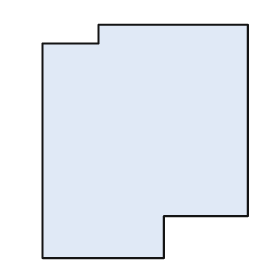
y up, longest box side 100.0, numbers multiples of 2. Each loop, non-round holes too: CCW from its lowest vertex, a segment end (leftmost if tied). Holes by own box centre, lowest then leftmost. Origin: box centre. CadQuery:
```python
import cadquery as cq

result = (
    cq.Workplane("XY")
    .moveTo(-44.0, -50.0)
    .lineTo(8.0, -50.0)
    .lineTo(8.0, -32.0)
    .lineTo(44.0, -32.0)
    .lineTo(44.0, 50.0)
    .lineTo(-20.0, 50.0)
    .lineTo(-20.0, 42.0)
    .lineTo(-44.0, 42.0)
    .close()
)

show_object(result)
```